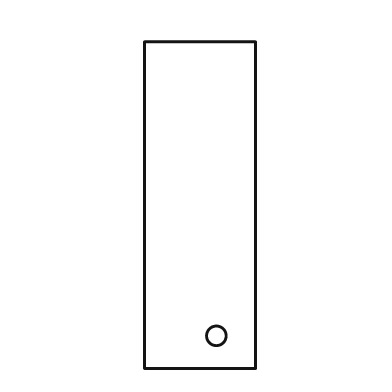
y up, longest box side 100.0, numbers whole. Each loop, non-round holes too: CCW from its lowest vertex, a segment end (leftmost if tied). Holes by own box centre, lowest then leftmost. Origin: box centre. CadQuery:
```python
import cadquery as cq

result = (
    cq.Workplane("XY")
    .moveTo(-17.0, -50.0)
    .lineTo(17.0, -50.0)
    .lineTo(17.0, 50.0)
    .lineTo(-17.0, 50.0)
    .close()
    .moveTo(5.0, -40.0)
    .circle(3.0)
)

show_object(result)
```